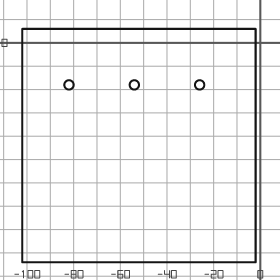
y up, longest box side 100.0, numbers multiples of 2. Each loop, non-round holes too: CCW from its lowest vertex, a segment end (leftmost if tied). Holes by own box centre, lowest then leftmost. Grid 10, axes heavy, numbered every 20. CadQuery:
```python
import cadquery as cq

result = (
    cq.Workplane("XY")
    .moveTo(-102.0, -94.0)
    .lineTo(-2.0, -94.0)
    .lineTo(-2.0, 6.0)
    .lineTo(-102.0, 6.0)
    .close()
    .moveTo(-82.0, -18.0)
    .circle(2.0)
    .moveTo(-54.0, -18.0)
    .circle(2.0)
    .moveTo(-26.0, -18.0)
    .circle(2.0)
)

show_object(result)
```